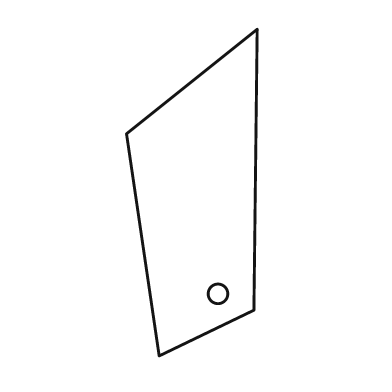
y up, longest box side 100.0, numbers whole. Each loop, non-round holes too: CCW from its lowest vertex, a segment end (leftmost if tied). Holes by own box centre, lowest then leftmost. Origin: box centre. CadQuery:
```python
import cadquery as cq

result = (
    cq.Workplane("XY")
    .moveTo(-10.0, -50.0)
    .lineTo(19.0, -36.0)
    .lineTo(20.0, 50.0)
    .lineTo(-20.0, 18.0)
    .close()
    .moveTo(8.0, -31.0)
    .circle(3.0)
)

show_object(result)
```